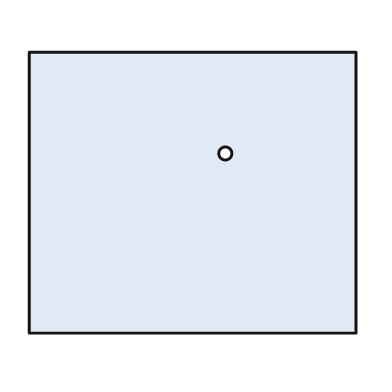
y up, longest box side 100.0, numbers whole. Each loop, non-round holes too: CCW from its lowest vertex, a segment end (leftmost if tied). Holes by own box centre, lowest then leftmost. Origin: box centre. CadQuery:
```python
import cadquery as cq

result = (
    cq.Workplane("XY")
    .moveTo(-50.0, -43.0)
    .lineTo(50.0, -43.0)
    .lineTo(50.0, 43.0)
    .lineTo(-50.0, 43.0)
    .close()
    .moveTo(10.0, 12.0)
    .circle(2.0)
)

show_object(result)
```